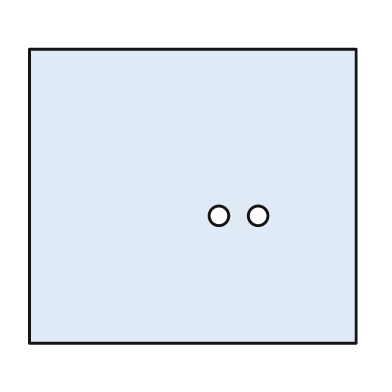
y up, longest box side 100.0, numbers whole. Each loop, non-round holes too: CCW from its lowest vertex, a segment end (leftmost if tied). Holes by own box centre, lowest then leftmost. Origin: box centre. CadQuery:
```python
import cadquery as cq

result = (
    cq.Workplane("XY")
    .moveTo(-50.0, -45.0)
    .lineTo(50.0, -45.0)
    .lineTo(50.0, 45.0)
    .lineTo(-50.0, 45.0)
    .close()
    .moveTo(8.0, -6.0)
    .circle(3.0)
    .moveTo(20.0, -6.0)
    .circle(3.0)
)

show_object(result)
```